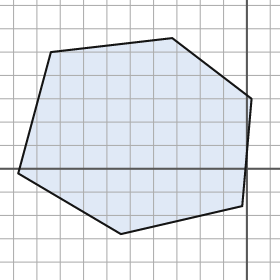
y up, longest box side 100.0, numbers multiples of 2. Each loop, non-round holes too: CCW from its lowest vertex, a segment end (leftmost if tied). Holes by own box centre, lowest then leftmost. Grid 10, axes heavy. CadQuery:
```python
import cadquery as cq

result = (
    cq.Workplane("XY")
    .moveTo(-54.0, -28.0)
    .lineTo(-2.0, -16.0)
    .lineTo(2.0, 30.0)
    .lineTo(-32.0, 56.0)
    .lineTo(-84.0, 50.0)
    .lineTo(-98.0, -2.0)
    .close()
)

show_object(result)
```